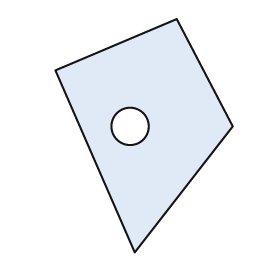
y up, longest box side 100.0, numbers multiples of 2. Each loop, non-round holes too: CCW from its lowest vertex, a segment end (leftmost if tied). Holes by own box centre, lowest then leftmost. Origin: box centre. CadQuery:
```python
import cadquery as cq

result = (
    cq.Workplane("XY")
    .moveTo(-4.0, -50.0)
    .lineTo(38.0, 4.0)
    .lineTo(14.0, 50.0)
    .lineTo(-38.0, 28.0)
    .close()
    .moveTo(-6.0, 4.0)
    .circle(8.0)
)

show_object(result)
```